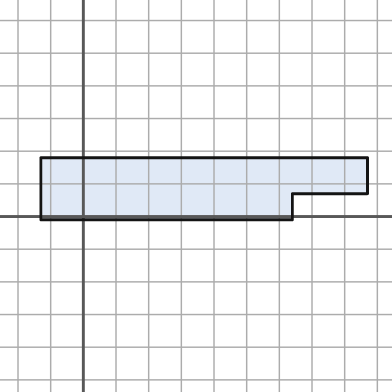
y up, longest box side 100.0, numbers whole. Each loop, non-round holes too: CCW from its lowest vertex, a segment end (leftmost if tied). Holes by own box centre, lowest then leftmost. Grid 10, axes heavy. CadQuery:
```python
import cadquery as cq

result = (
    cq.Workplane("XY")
    .moveTo(-13.0, -1.0)
    .lineTo(64.0, -1.0)
    .lineTo(64.0, 7.0)
    .lineTo(87.0, 7.0)
    .lineTo(87.0, 18.0)
    .lineTo(-13.0, 18.0)
    .close()
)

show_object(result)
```